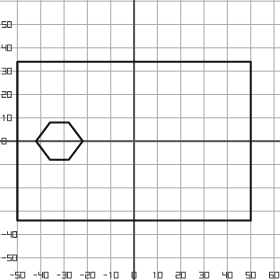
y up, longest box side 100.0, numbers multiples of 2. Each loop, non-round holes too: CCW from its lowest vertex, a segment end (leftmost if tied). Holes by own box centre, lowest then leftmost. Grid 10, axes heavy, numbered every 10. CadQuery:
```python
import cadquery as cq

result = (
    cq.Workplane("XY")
    .moveTo(-50.0, -34.0)
    .lineTo(50.0, -34.0)
    .lineTo(50.0, 34.0)
    .lineTo(-50.0, 34.0)
    .close()
    .moveTo(-36.0, -8.0)
    .lineTo(-28.0, -8.0)
    .lineTo(-22.0, 0.0)
    .lineTo(-28.0, 8.0)
    .lineTo(-36.0, 8.0)
    .lineTo(-42.0, 0.0)
    .close()
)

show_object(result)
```